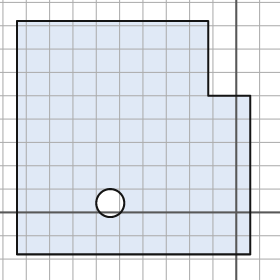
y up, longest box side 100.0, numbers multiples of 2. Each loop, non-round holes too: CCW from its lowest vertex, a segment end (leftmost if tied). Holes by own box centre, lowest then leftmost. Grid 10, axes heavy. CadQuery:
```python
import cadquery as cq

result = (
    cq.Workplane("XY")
    .moveTo(-94.0, -18.0)
    .lineTo(6.0, -18.0)
    .lineTo(6.0, 50.0)
    .lineTo(-12.0, 50.0)
    .lineTo(-12.0, 82.0)
    .lineTo(-94.0, 82.0)
    .close()
    .moveTo(-54.0, 4.0)
    .circle(6.0)
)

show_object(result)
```